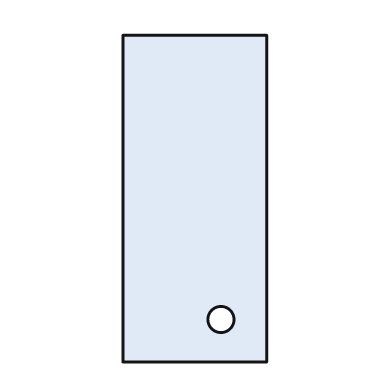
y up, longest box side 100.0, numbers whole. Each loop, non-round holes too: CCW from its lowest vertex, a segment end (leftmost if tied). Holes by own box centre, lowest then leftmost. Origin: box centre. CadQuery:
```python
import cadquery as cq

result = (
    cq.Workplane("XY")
    .moveTo(-22.0, -50.0)
    .lineTo(22.0, -50.0)
    .lineTo(22.0, 50.0)
    .lineTo(-22.0, 50.0)
    .close()
    .moveTo(8.0, -37.0)
    .circle(4.0)
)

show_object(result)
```